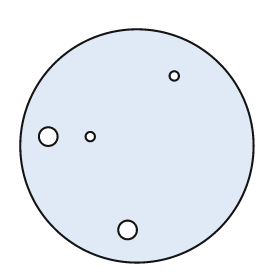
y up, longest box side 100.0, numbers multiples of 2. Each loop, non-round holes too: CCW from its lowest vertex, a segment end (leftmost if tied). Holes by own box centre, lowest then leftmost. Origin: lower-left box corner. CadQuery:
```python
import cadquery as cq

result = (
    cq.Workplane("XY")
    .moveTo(50.0, 50.0)
    .circle(50.0)
    .moveTo(46.0, 14.0)
    .circle(4.0)
    .moveTo(12.0, 54.0)
    .circle(4.0)
    .moveTo(30.0, 54.0)
    .circle(2.0)
    .moveTo(66.0, 80.0)
    .circle(2.0)
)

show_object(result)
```